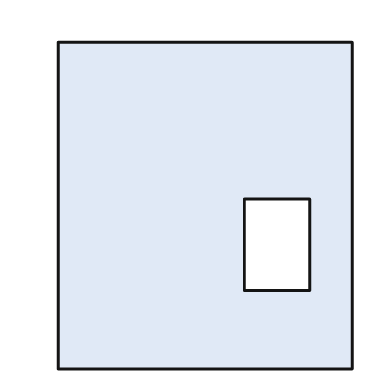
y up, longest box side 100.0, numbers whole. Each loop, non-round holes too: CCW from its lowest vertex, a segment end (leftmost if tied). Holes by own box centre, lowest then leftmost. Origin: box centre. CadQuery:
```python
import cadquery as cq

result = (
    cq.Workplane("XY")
    .moveTo(-45.0, -50.0)
    .lineTo(45.0, -50.0)
    .lineTo(45.0, 50.0)
    .lineTo(-45.0, 50.0)
    .close()
    .moveTo(12.0, -26.0)
    .lineTo(32.0, -26.0)
    .lineTo(32.0, 2.0)
    .lineTo(12.0, 2.0)
    .close()
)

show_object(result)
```